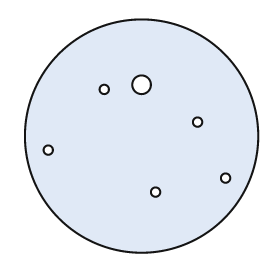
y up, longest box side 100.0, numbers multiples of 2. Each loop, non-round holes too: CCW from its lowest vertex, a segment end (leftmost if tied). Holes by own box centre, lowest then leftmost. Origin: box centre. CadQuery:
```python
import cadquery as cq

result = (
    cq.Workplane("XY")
    .moveTo(0.0, 0.0)
    .circle(50.0)
    .moveTo(6.0, -24.0)
    .circle(2.0)
    .moveTo(36.0, -18.0)
    .circle(2.0)
    .moveTo(-40.0, -6.0)
    .circle(2.0)
    .moveTo(24.0, 6.0)
    .circle(2.0)
    .moveTo(-16.0, 20.0)
    .circle(2.0)
    .moveTo(0.0, 22.0)
    .circle(4.0)
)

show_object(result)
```